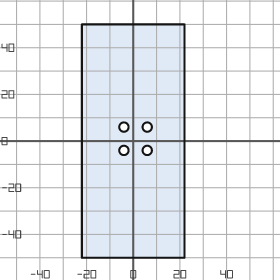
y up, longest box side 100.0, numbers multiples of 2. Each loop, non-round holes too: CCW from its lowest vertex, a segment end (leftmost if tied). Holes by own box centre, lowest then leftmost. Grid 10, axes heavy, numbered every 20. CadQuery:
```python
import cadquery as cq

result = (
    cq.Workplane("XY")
    .moveTo(-22.0, -50.0)
    .lineTo(22.0, -50.0)
    .lineTo(22.0, 50.0)
    .lineTo(-22.0, 50.0)
    .close()
    .moveTo(-4.0, -4.0)
    .circle(2.0)
    .moveTo(6.0, -4.0)
    .circle(2.0)
    .moveTo(-4.0, 6.0)
    .circle(2.0)
    .moveTo(6.0, 6.0)
    .circle(2.0)
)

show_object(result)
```